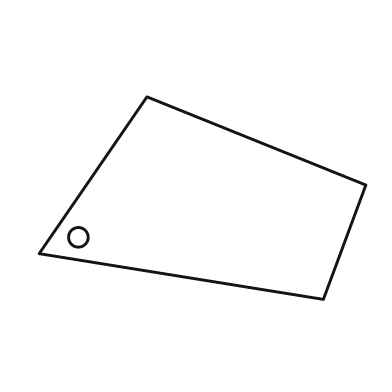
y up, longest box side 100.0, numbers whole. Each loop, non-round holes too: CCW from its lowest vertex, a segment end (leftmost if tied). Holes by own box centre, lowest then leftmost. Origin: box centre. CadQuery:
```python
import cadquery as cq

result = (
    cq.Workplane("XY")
    .moveTo(37.0, -31.0)
    .lineTo(50.0, 4.0)
    .lineTo(-17.0, 31.0)
    .lineTo(-50.0, -17.0)
    .close()
    .moveTo(-38.0, -12.0)
    .circle(3.0)
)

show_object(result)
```